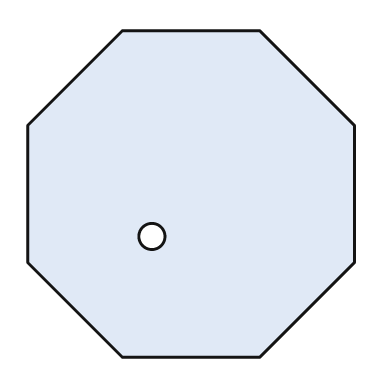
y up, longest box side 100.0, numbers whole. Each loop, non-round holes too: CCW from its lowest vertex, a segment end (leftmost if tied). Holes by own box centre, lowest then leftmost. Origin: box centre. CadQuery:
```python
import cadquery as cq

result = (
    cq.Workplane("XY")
    .moveTo(-21.0, -50.0)
    .lineTo(21.0, -50.0)
    .lineTo(50.0, -21.0)
    .lineTo(50.0, 21.0)
    .lineTo(21.0, 50.0)
    .lineTo(-21.0, 50.0)
    .lineTo(-50.0, 21.0)
    .lineTo(-50.0, -21.0)
    .close()
    .moveTo(-12.0, -13.0)
    .circle(4.0)
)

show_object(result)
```